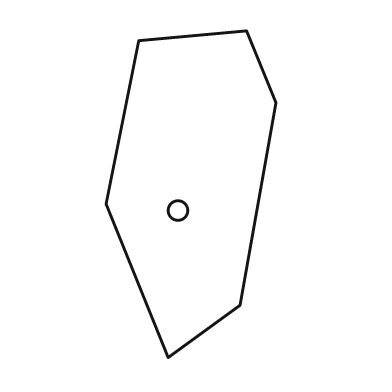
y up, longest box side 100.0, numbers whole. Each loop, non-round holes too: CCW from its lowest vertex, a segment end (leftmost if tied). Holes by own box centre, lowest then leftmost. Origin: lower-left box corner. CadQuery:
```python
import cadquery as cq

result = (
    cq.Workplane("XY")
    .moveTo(19.0, 0.0)
    .lineTo(41.0, 16.0)
    .lineTo(52.0, 78.0)
    .lineTo(43.0, 100.0)
    .lineTo(10.0, 97.0)
    .lineTo(0.0, 47.0)
    .close()
    .moveTo(22.0, 45.0)
    .circle(3.0)
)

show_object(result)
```